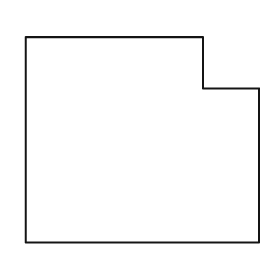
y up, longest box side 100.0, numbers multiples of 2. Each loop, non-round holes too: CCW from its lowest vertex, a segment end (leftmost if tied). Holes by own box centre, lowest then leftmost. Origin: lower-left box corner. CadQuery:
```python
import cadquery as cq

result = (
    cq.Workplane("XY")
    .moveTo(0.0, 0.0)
    .lineTo(100.0, 0.0)
    .lineTo(100.0, 66.0)
    .lineTo(76.0, 66.0)
    .lineTo(76.0, 88.0)
    .lineTo(0.0, 88.0)
    .close()
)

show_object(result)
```